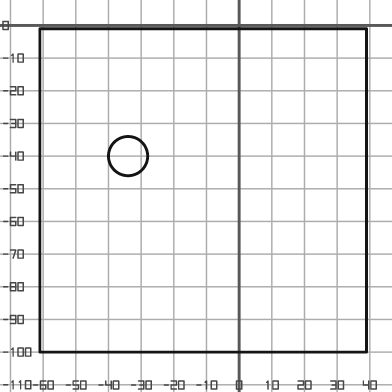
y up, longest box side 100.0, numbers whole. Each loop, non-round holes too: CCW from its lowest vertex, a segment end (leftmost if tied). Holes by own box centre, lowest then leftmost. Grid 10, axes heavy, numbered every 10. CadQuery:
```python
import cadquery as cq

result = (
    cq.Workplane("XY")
    .moveTo(-61.0, -100.0)
    .lineTo(39.0, -100.0)
    .lineTo(39.0, -1.0)
    .lineTo(-61.0, -1.0)
    .close()
    .moveTo(-34.0, -40.0)
    .circle(6.0)
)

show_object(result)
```